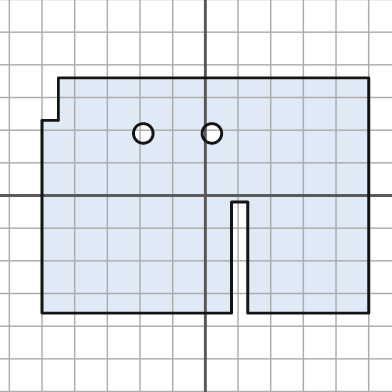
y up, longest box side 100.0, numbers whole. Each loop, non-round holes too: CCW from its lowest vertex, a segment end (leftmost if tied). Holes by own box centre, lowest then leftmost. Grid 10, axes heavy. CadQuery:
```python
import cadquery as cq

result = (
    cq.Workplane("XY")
    .moveTo(-50.0, -36.0)
    .lineTo(8.0, -36.0)
    .lineTo(8.0, -2.0)
    .lineTo(13.0, -2.0)
    .lineTo(13.0, -36.0)
    .lineTo(50.0, -36.0)
    .lineTo(50.0, 36.0)
    .lineTo(-45.0, 36.0)
    .lineTo(-45.0, 23.0)
    .lineTo(-50.0, 23.0)
    .close()
    .moveTo(-19.0, 19.0)
    .circle(3.0)
    .moveTo(2.0, 19.0)
    .circle(3.0)
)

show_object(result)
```